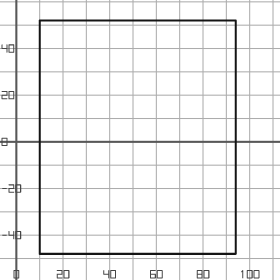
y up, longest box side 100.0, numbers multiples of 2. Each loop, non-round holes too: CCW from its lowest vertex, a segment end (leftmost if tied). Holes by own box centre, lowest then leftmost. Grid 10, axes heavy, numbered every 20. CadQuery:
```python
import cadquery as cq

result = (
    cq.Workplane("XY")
    .moveTo(10.0, -48.0)
    .lineTo(94.0, -48.0)
    .lineTo(94.0, 52.0)
    .lineTo(10.0, 52.0)
    .close()
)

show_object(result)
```